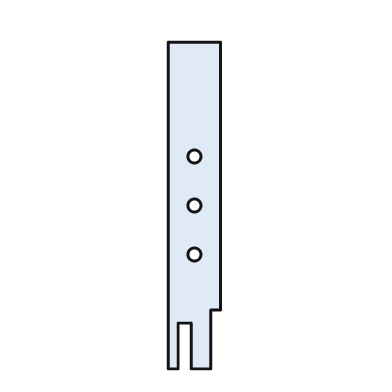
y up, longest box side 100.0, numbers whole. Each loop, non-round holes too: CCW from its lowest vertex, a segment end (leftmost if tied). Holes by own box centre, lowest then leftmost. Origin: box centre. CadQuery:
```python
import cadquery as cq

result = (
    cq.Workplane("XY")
    .moveTo(-8.0, -50.0)
    .lineTo(-5.0, -50.0)
    .lineTo(-5.0, -36.0)
    .lineTo(-1.0, -36.0)
    .lineTo(-1.0, -50.0)
    .lineTo(5.0, -50.0)
    .lineTo(5.0, -32.0)
    .lineTo(8.0, -32.0)
    .lineTo(8.0, 50.0)
    .lineTo(-8.0, 50.0)
    .close()
    .moveTo(0.0, -15.0)
    .circle(2.0)
    .moveTo(0.0, 0.0)
    .circle(2.0)
    .moveTo(0.0, 15.0)
    .circle(2.0)
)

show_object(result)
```